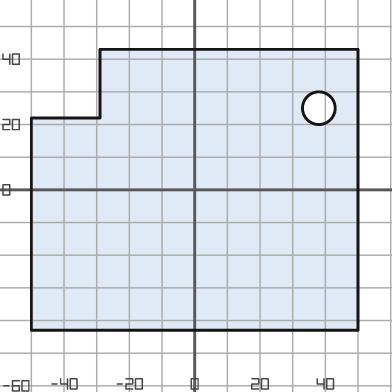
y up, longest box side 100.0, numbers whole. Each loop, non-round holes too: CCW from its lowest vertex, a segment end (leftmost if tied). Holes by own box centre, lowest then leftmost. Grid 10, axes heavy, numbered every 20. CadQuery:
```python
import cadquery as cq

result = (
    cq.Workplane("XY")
    .moveTo(-50.0, -43.0)
    .lineTo(50.0, -43.0)
    .lineTo(50.0, 43.0)
    .lineTo(-29.0, 43.0)
    .lineTo(-29.0, 22.0)
    .lineTo(-50.0, 22.0)
    .close()
    .moveTo(38.0, 25.0)
    .circle(5.0)
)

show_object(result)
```